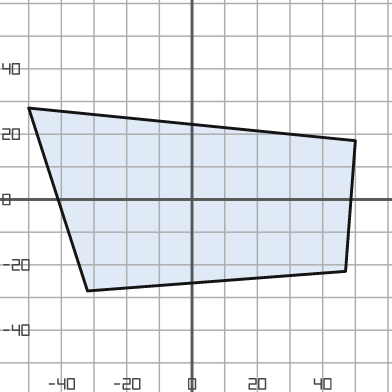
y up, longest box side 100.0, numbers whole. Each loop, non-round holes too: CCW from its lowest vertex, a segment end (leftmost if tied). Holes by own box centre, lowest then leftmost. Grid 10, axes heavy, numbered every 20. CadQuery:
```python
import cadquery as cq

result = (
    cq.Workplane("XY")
    .moveTo(-32.0, -28.0)
    .lineTo(47.0, -22.0)
    .lineTo(50.0, 18.0)
    .lineTo(-50.0, 28.0)
    .close()
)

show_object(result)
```